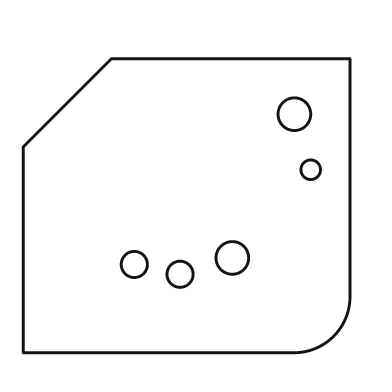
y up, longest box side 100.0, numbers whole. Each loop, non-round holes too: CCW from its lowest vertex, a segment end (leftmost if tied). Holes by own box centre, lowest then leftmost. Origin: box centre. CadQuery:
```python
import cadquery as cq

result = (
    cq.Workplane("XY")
    .moveTo(-50.0, -45.0)
    .lineTo(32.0, -45.0)
    .threePointArc((45.0, -40.0), (50.0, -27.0))
    .lineTo(50.0, 45.0)
    .lineTo(-23.0, 45.0)
    .lineTo(-50.0, 18.0)
    .close()
    .moveTo(-2.0, -21.0)
    .circle(4.0)
    .moveTo(-16.0, -18.0)
    .circle(4.0)
    .moveTo(14.0, -16.0)
    .circle(5.0)
    .moveTo(38.0, 11.0)
    .circle(3.0)
    .moveTo(33.0, 28.0)
    .circle(5.0)
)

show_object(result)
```